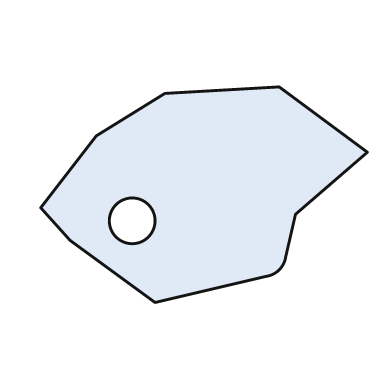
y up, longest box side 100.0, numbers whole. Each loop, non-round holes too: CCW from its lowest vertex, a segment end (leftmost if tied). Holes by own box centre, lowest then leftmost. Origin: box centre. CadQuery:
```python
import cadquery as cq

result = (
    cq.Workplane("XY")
    .moveTo(-15.0, -33.0)
    .lineTo(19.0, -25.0)
    .threePointArc((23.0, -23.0), (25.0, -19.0))
    .lineTo(28.0, -6.0)
    .lineTo(50.0, 13.0)
    .lineTo(23.0, 33.0)
    .lineTo(-12.0, 31.0)
    .lineTo(-33.0, 18.0)
    .lineTo(-50.0, -4.0)
    .lineTo(-41.0, -14.0)
    .close()
    .moveTo(-22.0, -8.0)
    .circle(7.0)
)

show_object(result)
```